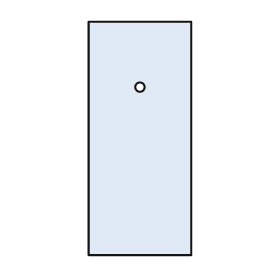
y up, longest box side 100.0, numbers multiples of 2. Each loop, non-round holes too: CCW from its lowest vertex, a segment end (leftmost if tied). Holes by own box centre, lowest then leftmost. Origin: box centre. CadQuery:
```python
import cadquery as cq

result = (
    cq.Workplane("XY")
    .moveTo(-22.0, -50.0)
    .lineTo(22.0, -50.0)
    .lineTo(22.0, 50.0)
    .lineTo(-22.0, 50.0)
    .close()
    .moveTo(0.0, 22.0)
    .circle(2.0)
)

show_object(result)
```